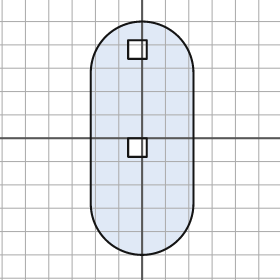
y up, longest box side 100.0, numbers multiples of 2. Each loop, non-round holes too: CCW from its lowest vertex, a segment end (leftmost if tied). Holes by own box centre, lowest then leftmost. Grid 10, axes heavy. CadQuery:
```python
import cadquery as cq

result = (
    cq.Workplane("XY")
    .moveTo(-22.0, -28.0)
    .threePointArc((0.0, -50.0), (22.0, -28.0))
    .lineTo(22.0, 28.0)
    .threePointArc((0.0, 50.0), (-22.0, 28.0))
    .close()
    .moveTo(-6.0, -8.0)
    .lineTo(2.0, -8.0)
    .lineTo(2.0, 0.0)
    .lineTo(-6.0, 0.0)
    .close()
    .moveTo(-6.0, 34.0)
    .lineTo(2.0, 34.0)
    .lineTo(2.0, 42.0)
    .lineTo(-6.0, 42.0)
    .close()
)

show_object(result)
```